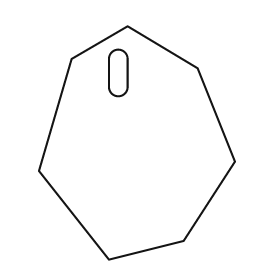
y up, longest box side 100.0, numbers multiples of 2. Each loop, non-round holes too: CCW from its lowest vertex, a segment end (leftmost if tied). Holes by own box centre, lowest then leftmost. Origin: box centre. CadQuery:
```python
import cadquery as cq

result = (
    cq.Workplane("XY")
    .moveTo(-12.0, -50.0)
    .lineTo(20.0, -42.0)
    .lineTo(42.0, -8.0)
    .lineTo(26.0, 32.0)
    .lineTo(-4.0, 50.0)
    .lineTo(-28.0, 36.0)
    .lineTo(-42.0, -12.0)
    .close()
    .moveTo(-12.0, 24.0)
    .threePointArc((-8.0, 20.0), (-4.0, 24.0))
    .lineTo(-4.0, 36.0)
    .threePointArc((-8.0, 40.0), (-12.0, 36.0))
    .close()
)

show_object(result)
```